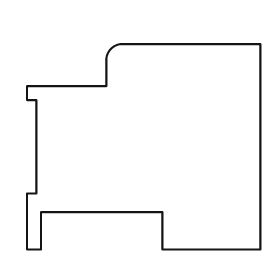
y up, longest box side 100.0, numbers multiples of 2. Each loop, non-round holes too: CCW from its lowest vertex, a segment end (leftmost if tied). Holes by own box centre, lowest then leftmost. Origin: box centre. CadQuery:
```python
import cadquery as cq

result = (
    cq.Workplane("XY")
    .moveTo(-50.0, -44.0)
    .lineTo(-44.0, -44.0)
    .lineTo(-44.0, -28.0)
    .lineTo(8.0, -28.0)
    .lineTo(8.0, -44.0)
    .lineTo(50.0, -44.0)
    .lineTo(50.0, 44.0)
    .lineTo(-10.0, 44.0)
    .threePointArc((-14.0, 42.0), (-16.0, 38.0))
    .lineTo(-16.0, 26.0)
    .lineTo(-50.0, 26.0)
    .lineTo(-50.0, 20.0)
    .lineTo(-46.0, 20.0)
    .lineTo(-46.0, -20.0)
    .lineTo(-50.0, -20.0)
    .close()
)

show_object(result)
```